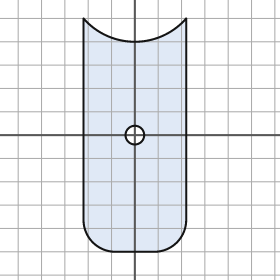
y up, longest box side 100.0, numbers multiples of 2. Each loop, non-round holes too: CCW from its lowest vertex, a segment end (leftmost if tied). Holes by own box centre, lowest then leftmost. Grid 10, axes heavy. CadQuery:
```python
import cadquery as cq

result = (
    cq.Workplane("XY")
    .moveTo(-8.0, -50.0)
    .lineTo(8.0, -50.0)
    .threePointArc((18.0, -46.0), (22.0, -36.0))
    .lineTo(22.0, 50.0)
    .threePointArc((0.0, 40.0), (-22.0, 50.0))
    .lineTo(-22.0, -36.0)
    .threePointArc((-18.0, -46.0), (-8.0, -50.0))
    .close()
    .moveTo(0.0, 0.0)
    .circle(4.0)
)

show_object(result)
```